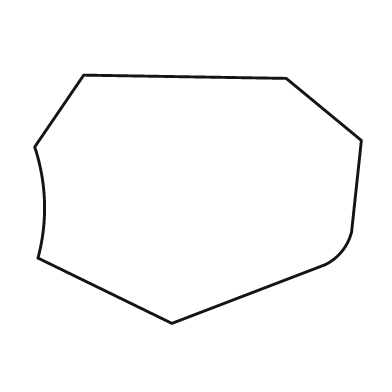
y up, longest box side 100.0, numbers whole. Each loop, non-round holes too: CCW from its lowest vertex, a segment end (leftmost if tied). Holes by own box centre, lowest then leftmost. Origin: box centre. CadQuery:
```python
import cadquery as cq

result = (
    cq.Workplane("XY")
    .moveTo(-8.0, -38.0)
    .lineTo(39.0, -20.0)
    .threePointArc((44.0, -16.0), (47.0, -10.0))
    .lineTo(50.0, 18.0)
    .lineTo(27.0, 37.0)
    .lineTo(-35.0, 38.0)
    .lineTo(-50.0, 16.0)
    .threePointArc((-47.0, -1.0), (-49.0, -18.0))
    .close()
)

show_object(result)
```